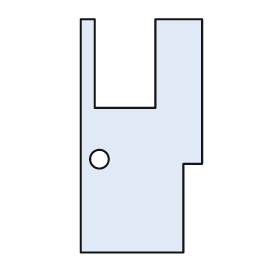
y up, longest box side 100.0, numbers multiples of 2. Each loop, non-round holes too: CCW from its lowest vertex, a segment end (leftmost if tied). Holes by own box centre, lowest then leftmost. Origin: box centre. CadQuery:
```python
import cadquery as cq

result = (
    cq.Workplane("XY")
    .moveTo(-26.0, -50.0)
    .lineTo(18.0, -50.0)
    .lineTo(18.0, -12.0)
    .lineTo(26.0, -12.0)
    .lineTo(26.0, 50.0)
    .lineTo(6.0, 50.0)
    .lineTo(6.0, 12.0)
    .lineTo(-20.0, 12.0)
    .lineTo(-20.0, 50.0)
    .lineTo(-26.0, 50.0)
    .close()
    .moveTo(-18.0, -10.0)
    .circle(4.0)
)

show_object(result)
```